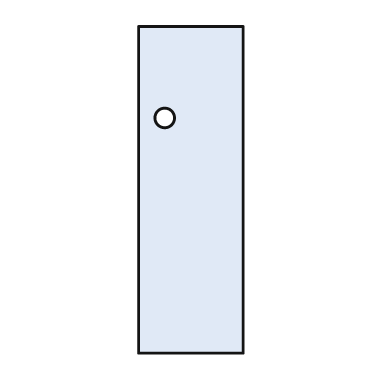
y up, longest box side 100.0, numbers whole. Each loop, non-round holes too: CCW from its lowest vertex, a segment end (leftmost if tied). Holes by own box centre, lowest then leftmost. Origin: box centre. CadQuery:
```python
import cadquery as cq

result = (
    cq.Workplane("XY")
    .moveTo(-16.0, -50.0)
    .lineTo(16.0, -50.0)
    .lineTo(16.0, 50.0)
    .lineTo(-16.0, 50.0)
    .close()
    .moveTo(-8.0, 22.0)
    .circle(3.0)
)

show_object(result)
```